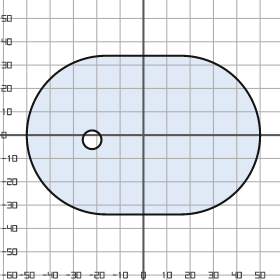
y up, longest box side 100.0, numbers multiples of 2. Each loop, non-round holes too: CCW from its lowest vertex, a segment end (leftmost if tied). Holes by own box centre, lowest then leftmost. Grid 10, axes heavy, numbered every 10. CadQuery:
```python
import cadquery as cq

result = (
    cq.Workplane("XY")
    .moveTo(-16.0, -34.0)
    .lineTo(16.0, -34.0)
    .threePointArc((50.0, 0.0), (16.0, 34.0))
    .lineTo(-16.0, 34.0)
    .threePointArc((-50.0, 0.0), (-16.0, -34.0))
    .close()
    .moveTo(-22.0, -2.0)
    .circle(4.0)
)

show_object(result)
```